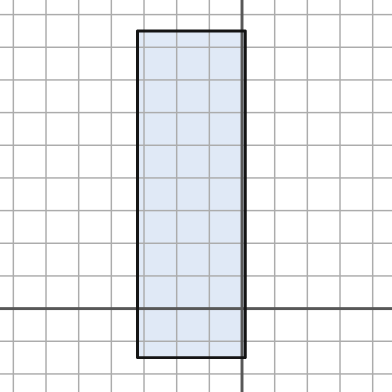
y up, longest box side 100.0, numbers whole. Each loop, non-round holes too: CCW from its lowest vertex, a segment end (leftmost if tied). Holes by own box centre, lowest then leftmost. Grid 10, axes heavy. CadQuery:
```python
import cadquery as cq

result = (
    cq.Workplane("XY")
    .moveTo(-32.0, -15.0)
    .lineTo(1.0, -15.0)
    .lineTo(1.0, 85.0)
    .lineTo(-32.0, 85.0)
    .close()
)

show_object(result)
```